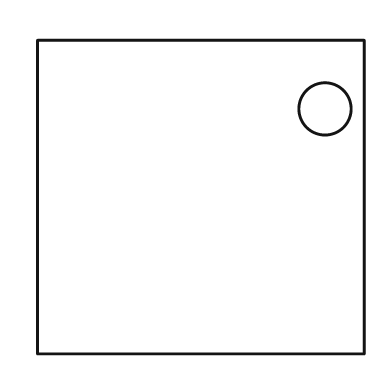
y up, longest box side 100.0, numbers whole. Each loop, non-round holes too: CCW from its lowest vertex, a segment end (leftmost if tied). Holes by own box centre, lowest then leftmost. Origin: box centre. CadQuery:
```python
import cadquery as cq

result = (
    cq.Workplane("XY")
    .moveTo(-50.0, -48.0)
    .lineTo(50.0, -48.0)
    .lineTo(50.0, 48.0)
    .lineTo(-50.0, 48.0)
    .close()
    .moveTo(38.0, 27.0)
    .circle(8.0)
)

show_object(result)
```